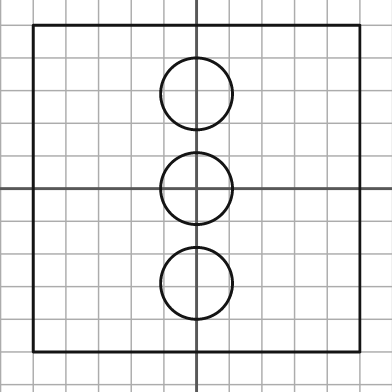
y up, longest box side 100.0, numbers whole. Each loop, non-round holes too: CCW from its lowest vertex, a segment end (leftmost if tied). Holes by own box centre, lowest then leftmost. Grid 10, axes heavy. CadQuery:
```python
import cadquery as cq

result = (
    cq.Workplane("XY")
    .moveTo(-50.0, -50.0)
    .lineTo(50.0, -50.0)
    .lineTo(50.0, 50.0)
    .lineTo(-50.0, 50.0)
    .close()
    .moveTo(0.0, -29.0)
    .circle(11.0)
    .moveTo(0.0, 0.0)
    .circle(11.0)
    .moveTo(0.0, 29.0)
    .circle(11.0)
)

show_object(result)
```